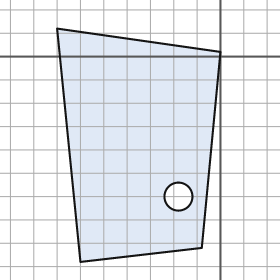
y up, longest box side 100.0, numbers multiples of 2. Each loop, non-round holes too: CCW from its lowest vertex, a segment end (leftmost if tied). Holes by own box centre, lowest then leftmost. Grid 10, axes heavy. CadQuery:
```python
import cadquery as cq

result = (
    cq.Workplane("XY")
    .moveTo(-60.0, -88.0)
    .lineTo(-8.0, -82.0)
    .lineTo(0.0, 2.0)
    .lineTo(-70.0, 12.0)
    .close()
    .moveTo(-18.0, -60.0)
    .circle(6.0)
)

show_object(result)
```